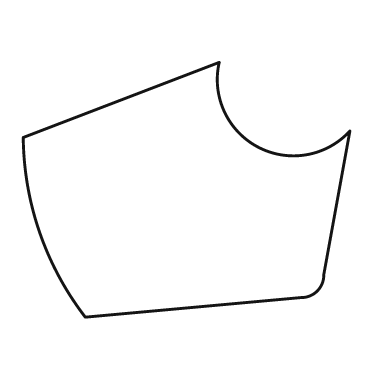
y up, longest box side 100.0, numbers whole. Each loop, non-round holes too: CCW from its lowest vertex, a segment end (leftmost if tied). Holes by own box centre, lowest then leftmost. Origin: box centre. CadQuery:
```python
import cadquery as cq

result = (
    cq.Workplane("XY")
    .moveTo(-31.0, -39.0)
    .lineTo(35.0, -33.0)
    .threePointArc((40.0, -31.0), (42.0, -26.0))
    .lineTo(50.0, 18.0)
    .threePointArc((22.0, 13.0), (10.0, 39.0))
    .lineTo(-50.0, 16.0)
    .threePointArc((-45.0, -13.0), (-31.0, -39.0))
    .close()
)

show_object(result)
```